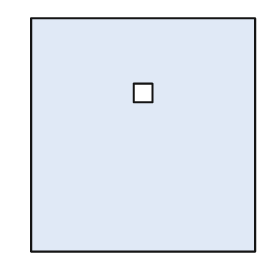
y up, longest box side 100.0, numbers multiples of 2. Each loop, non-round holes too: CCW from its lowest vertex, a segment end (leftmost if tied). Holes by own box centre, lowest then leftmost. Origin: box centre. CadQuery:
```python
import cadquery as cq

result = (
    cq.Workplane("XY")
    .moveTo(-48.0, -50.0)
    .lineTo(48.0, -50.0)
    .lineTo(48.0, 50.0)
    .lineTo(-48.0, 50.0)
    .close()
    .moveTo(-4.0, 14.0)
    .lineTo(4.0, 14.0)
    .lineTo(4.0, 22.0)
    .lineTo(-4.0, 22.0)
    .close()
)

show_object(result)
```